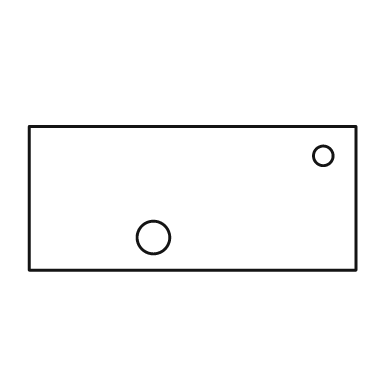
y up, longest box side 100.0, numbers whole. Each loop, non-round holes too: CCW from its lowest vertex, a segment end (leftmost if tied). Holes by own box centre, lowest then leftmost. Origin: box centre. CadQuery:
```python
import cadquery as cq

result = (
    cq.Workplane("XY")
    .moveTo(-50.0, -22.0)
    .lineTo(50.0, -22.0)
    .lineTo(50.0, 22.0)
    .lineTo(-50.0, 22.0)
    .close()
    .moveTo(-12.0, -12.0)
    .circle(5.0)
    .moveTo(40.0, 13.0)
    .circle(3.0)
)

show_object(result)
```